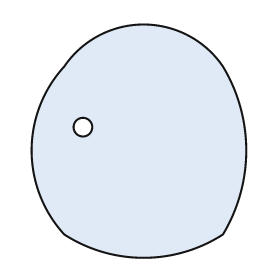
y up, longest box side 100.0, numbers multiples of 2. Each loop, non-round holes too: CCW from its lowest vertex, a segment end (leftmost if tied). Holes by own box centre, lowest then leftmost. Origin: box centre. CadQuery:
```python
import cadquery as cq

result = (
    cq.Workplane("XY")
    .moveTo(-32.0, -40.0)
    .threePointArc((2.0, -50.0), (36.0, -40.0))
    .threePointArc((46.0, -4.0), (36.0, 32.0))
    .threePointArc((2.0, 50.0), (-32.0, 32.0))
    .threePointArc((-46.0, -4.0), (-32.0, -40.0))
    .close()
    .moveTo(-24.0, 6.0)
    .circle(4.0)
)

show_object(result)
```